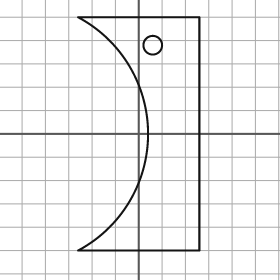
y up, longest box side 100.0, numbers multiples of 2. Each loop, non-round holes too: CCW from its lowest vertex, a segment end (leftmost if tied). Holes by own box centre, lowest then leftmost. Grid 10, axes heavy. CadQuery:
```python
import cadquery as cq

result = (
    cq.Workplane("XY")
    .moveTo(-26.0, -50.0)
    .lineTo(26.0, -50.0)
    .lineTo(26.0, 50.0)
    .lineTo(-26.0, 50.0)
    .threePointArc((4.0, 0.0), (-26.0, -50.0))
    .close()
    .moveTo(6.0, 38.0)
    .circle(4.0)
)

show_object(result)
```